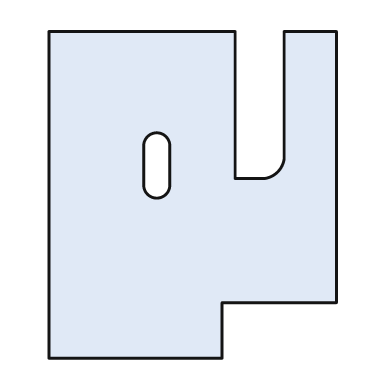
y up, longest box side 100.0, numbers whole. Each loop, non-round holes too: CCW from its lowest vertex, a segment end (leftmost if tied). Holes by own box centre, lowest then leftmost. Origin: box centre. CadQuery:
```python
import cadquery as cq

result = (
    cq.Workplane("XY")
    .moveTo(-44.0, -50.0)
    .lineTo(9.0, -50.0)
    .lineTo(9.0, -33.0)
    .lineTo(44.0, -33.0)
    .lineTo(44.0, 50.0)
    .lineTo(28.0, 50.0)
    .lineTo(28.0, 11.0)
    .threePointArc((26.0, 7.0), (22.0, 5.0))
    .lineTo(13.0, 5.0)
    .lineTo(13.0, 50.0)
    .lineTo(-44.0, 50.0)
    .close()
    .moveTo(-15.0, 3.0)
    .threePointArc((-11.0, -1.0), (-7.0, 3.0))
    .lineTo(-7.0, 15.0)
    .threePointArc((-11.0, 19.0), (-15.0, 15.0))
    .close()
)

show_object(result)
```